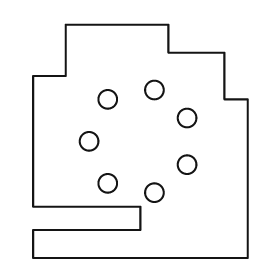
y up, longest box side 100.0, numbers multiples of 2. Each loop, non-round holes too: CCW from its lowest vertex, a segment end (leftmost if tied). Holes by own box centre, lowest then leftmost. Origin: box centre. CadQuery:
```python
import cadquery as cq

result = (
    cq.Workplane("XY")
    .moveTo(-46.0, -50.0)
    .lineTo(46.0, -50.0)
    .lineTo(46.0, 18.0)
    .lineTo(36.0, 18.0)
    .lineTo(36.0, 38.0)
    .lineTo(12.0, 38.0)
    .lineTo(12.0, 50.0)
    .lineTo(-32.0, 50.0)
    .lineTo(-32.0, 28.0)
    .lineTo(-46.0, 28.0)
    .lineTo(-46.0, -28.0)
    .lineTo(0.0, -28.0)
    .lineTo(0.0, -38.0)
    .lineTo(-46.0, -38.0)
    .close()
    .moveTo(6.0, -22.0)
    .circle(4.0)
    .moveTo(-14.0, -18.0)
    .circle(4.0)
    .moveTo(20.0, -10.0)
    .circle(4.0)
    .moveTo(-22.0, 0.0)
    .circle(4.0)
    .moveTo(20.0, 10.0)
    .circle(4.0)
    .moveTo(-14.0, 18.0)
    .circle(4.0)
    .moveTo(6.0, 22.0)
    .circle(4.0)
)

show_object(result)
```